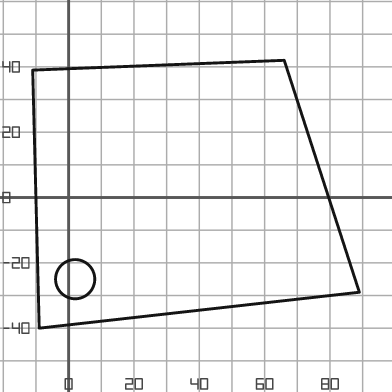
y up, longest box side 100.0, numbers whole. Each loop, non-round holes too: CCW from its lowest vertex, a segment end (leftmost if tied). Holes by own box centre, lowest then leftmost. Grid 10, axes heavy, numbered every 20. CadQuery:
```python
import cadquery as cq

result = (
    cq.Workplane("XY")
    .moveTo(-9.0, -40.0)
    .lineTo(89.0, -29.0)
    .lineTo(66.0, 42.0)
    .lineTo(-11.0, 39.0)
    .close()
    .moveTo(2.0, -25.0)
    .circle(6.0)
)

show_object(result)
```